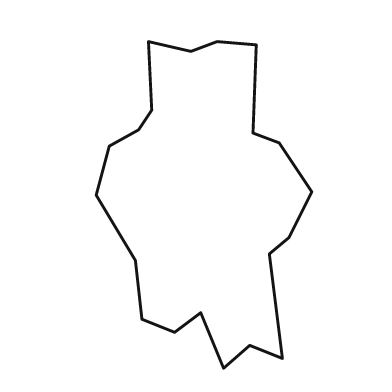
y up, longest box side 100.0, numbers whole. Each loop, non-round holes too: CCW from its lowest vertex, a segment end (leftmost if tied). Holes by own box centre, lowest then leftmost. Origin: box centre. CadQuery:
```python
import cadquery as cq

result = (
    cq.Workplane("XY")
    .moveTo(6.0, -50.0)
    .lineTo(14.0, -43.0)
    .lineTo(24.0, -47.0)
    .lineTo(20.0, -15.0)
    .lineTo(26.0, -10.0)
    .lineTo(33.0, 4.0)
    .lineTo(23.0, 19.0)
    .lineTo(15.0, 22.0)
    .lineTo(16.0, 49.0)
    .lineTo(4.0, 50.0)
    .lineTo(-4.0, 47.0)
    .lineTo(-17.0, 50.0)
    .lineTo(-16.0, 29.0)
    .lineTo(-20.0, 23.0)
    .lineTo(-29.0, 18.0)
    .lineTo(-33.0, 3.0)
    .lineTo(-21.0, -17.0)
    .lineTo(-19.0, -35.0)
    .lineTo(-9.0, -39.0)
    .lineTo(-1.0, -33.0)
    .close()
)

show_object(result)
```